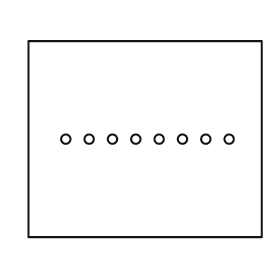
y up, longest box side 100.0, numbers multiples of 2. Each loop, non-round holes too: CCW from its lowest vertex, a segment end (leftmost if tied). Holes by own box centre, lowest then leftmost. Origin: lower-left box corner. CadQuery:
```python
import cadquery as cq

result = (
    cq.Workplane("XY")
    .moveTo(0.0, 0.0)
    .lineTo(100.0, 0.0)
    .lineTo(100.0, 84.0)
    .lineTo(0.0, 84.0)
    .close()
    .moveTo(16.0, 42.0)
    .circle(2.0)
    .moveTo(26.0, 42.0)
    .circle(2.0)
    .moveTo(36.0, 42.0)
    .circle(2.0)
    .moveTo(46.0, 42.0)
    .circle(2.0)
    .moveTo(56.0, 42.0)
    .circle(2.0)
    .moveTo(66.0, 42.0)
    .circle(2.0)
    .moveTo(76.0, 42.0)
    .circle(2.0)
    .moveTo(86.0, 42.0)
    .circle(2.0)
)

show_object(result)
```